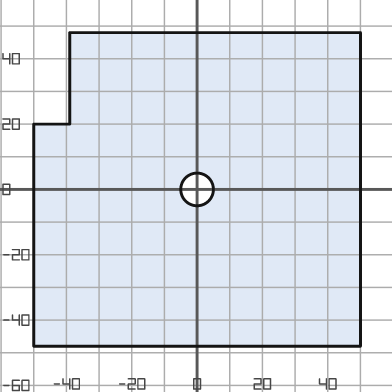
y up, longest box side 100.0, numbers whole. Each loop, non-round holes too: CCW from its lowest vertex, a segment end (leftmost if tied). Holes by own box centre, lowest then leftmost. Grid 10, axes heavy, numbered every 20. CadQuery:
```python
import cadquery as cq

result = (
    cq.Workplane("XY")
    .moveTo(-50.0, -48.0)
    .lineTo(50.0, -48.0)
    .lineTo(50.0, 48.0)
    .lineTo(-39.0, 48.0)
    .lineTo(-39.0, 20.0)
    .lineTo(-50.0, 20.0)
    .close()
    .moveTo(0.0, 0.0)
    .circle(5.0)
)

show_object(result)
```